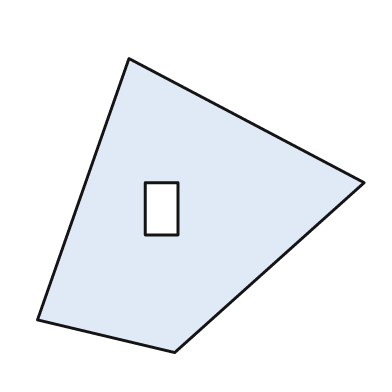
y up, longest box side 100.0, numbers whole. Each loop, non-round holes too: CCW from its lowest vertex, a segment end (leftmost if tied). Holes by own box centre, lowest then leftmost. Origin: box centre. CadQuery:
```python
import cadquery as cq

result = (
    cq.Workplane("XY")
    .moveTo(-8.0, -45.0)
    .lineTo(50.0, 7.0)
    .lineTo(-22.0, 45.0)
    .lineTo(-50.0, -35.0)
    .close()
    .moveTo(-17.0, -9.0)
    .lineTo(-7.0, -9.0)
    .lineTo(-7.0, 7.0)
    .lineTo(-17.0, 7.0)
    .close()
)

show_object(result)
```